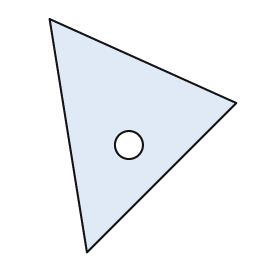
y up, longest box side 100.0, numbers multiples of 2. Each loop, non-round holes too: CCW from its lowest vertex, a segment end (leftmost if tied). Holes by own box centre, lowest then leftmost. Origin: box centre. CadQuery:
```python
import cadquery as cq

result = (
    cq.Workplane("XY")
    .moveTo(-24.0, -50.0)
    .lineTo(40.0, 14.0)
    .lineTo(-40.0, 50.0)
    .close()
    .moveTo(-6.0, -4.0)
    .circle(6.0)
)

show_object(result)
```